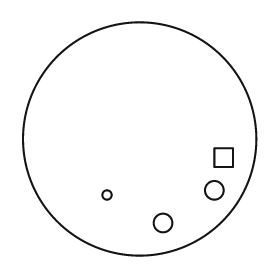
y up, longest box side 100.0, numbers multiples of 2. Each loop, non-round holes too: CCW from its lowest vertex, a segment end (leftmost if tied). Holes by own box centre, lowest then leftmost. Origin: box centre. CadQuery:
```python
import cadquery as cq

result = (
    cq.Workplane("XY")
    .moveTo(0.0, 0.0)
    .circle(50.0)
    .moveTo(10.0, -36.0)
    .circle(4.0)
    .moveTo(-14.0, -24.0)
    .circle(2.0)
    .moveTo(32.0, -22.0)
    .circle(4.0)
    .moveTo(32.0, -12.0)
    .lineTo(40.0, -12.0)
    .lineTo(40.0, -4.0)
    .lineTo(32.0, -4.0)
    .close()
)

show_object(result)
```